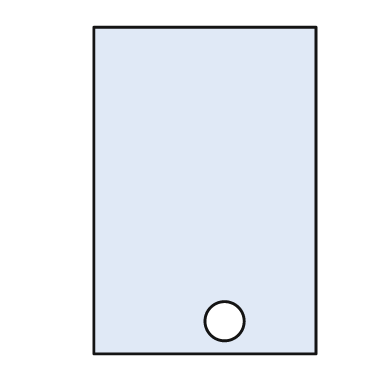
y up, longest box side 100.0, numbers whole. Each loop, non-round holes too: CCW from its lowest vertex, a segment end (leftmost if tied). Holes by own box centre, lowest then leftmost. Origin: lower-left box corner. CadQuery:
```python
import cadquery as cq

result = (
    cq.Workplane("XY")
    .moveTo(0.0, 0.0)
    .lineTo(68.0, 0.0)
    .lineTo(68.0, 100.0)
    .lineTo(0.0, 100.0)
    .close()
    .moveTo(40.0, 10.0)
    .circle(6.0)
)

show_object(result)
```